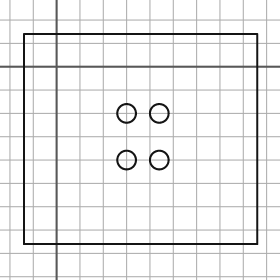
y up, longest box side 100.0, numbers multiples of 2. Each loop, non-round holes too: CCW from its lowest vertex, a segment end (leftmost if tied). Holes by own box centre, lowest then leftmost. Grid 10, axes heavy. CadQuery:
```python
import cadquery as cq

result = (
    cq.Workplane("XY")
    .moveTo(-14.0, -76.0)
    .lineTo(86.0, -76.0)
    .lineTo(86.0, 14.0)
    .lineTo(-14.0, 14.0)
    .close()
    .moveTo(30.0, -40.0)
    .circle(4.0)
    .moveTo(44.0, -40.0)
    .circle(4.0)
    .moveTo(30.0, -20.0)
    .circle(4.0)
    .moveTo(44.0, -20.0)
    .circle(4.0)
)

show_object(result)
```